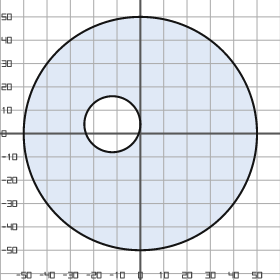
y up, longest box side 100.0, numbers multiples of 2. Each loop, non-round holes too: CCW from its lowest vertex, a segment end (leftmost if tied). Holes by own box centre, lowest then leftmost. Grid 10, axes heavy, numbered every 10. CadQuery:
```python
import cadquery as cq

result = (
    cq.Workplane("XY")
    .moveTo(0.0, 0.0)
    .circle(50.0)
    .moveTo(-12.0, 4.0)
    .circle(12.0)
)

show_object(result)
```